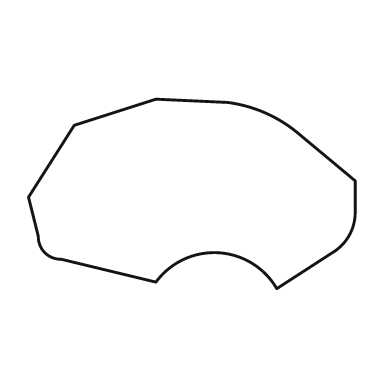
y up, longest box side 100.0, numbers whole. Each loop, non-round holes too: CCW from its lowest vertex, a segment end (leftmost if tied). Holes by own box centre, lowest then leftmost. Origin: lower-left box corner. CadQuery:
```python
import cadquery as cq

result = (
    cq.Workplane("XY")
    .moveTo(76.0, 0.0)
    .lineTo(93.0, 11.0)
    .threePointArc((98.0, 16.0), (100.0, 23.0))
    .lineTo(100.0, 33.0)
    .lineTo(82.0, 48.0)
    .threePointArc((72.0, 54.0), (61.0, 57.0))
    .lineTo(39.0, 58.0)
    .lineTo(14.0, 50.0)
    .lineTo(0.0, 28.0)
    .lineTo(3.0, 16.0)
    .threePointArc((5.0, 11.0), (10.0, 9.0))
    .lineTo(39.0, 2.0)
    .threePointArc((58.0, 11.0), (76.0, 0.0))
    .close()
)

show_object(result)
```